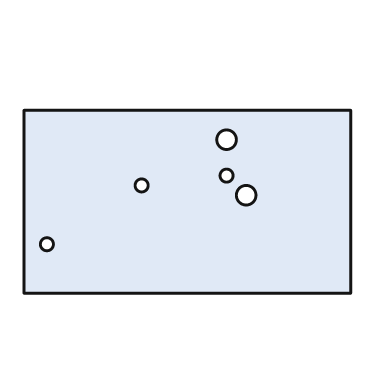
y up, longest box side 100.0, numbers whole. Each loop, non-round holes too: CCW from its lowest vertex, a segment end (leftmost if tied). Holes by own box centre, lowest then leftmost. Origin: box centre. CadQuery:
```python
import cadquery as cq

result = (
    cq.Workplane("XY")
    .moveTo(-50.0, -28.0)
    .lineTo(50.0, -28.0)
    .lineTo(50.0, 28.0)
    .lineTo(-50.0, 28.0)
    .close()
    .moveTo(-43.0, -13.0)
    .circle(2.0)
    .moveTo(18.0, 2.0)
    .circle(3.0)
    .moveTo(-14.0, 5.0)
    .circle(2.0)
    .moveTo(12.0, 8.0)
    .circle(2.0)
    .moveTo(12.0, 19.0)
    .circle(3.0)
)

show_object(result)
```